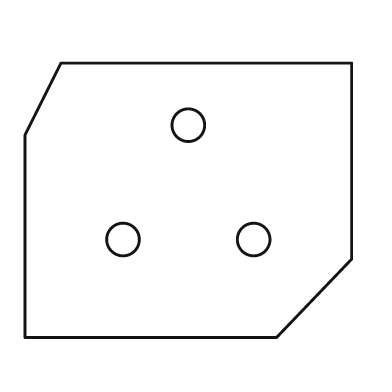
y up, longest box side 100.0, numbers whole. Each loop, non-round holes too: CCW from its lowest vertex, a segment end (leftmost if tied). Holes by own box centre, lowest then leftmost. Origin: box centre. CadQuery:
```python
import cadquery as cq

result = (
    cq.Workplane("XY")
    .moveTo(-50.0, -42.0)
    .lineTo(27.0, -42.0)
    .lineTo(50.0, -18.0)
    .lineTo(50.0, 42.0)
    .lineTo(-39.0, 42.0)
    .lineTo(-50.0, 20.0)
    .close()
    .moveTo(-20.0, -12.0)
    .circle(5.0)
    .moveTo(20.0, -12.0)
    .circle(5.0)
    .moveTo(0.0, 23.0)
    .circle(5.0)
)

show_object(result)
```